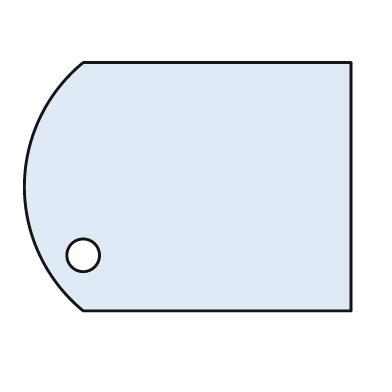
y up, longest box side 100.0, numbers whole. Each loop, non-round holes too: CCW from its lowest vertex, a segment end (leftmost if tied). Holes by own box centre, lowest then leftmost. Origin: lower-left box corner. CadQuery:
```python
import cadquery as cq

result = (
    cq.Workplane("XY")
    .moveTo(18.0, 0.0)
    .lineTo(100.0, 0.0)
    .lineTo(100.0, 76.0)
    .lineTo(18.0, 76.0)
    .threePointArc((0.0, 38.0), (18.0, 0.0))
    .close()
    .moveTo(18.0, 17.0)
    .circle(5.0)
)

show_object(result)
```